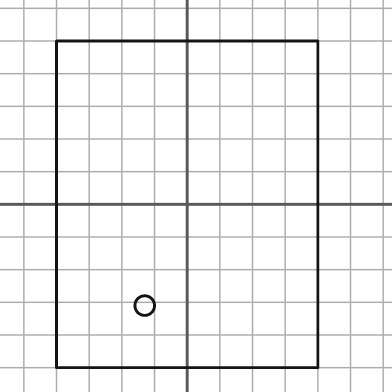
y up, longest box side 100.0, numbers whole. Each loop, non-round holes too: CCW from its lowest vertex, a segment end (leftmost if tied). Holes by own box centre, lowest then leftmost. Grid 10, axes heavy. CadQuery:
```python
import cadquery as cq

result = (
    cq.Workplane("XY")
    .moveTo(-40.0, -50.0)
    .lineTo(40.0, -50.0)
    .lineTo(40.0, 50.0)
    .lineTo(-40.0, 50.0)
    .close()
    .moveTo(-13.0, -31.0)
    .circle(3.0)
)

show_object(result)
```